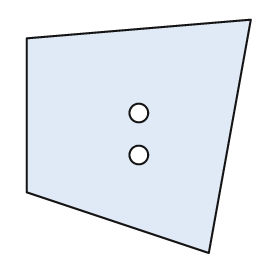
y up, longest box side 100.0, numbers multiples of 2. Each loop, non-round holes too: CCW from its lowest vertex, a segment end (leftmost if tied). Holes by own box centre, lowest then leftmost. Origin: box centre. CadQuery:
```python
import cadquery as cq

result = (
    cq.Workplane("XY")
    .moveTo(30.0, -50.0)
    .lineTo(48.0, 50.0)
    .lineTo(-48.0, 42.0)
    .lineTo(-48.0, -24.0)
    .close()
    .moveTo(0.0, -8.0)
    .circle(4.0)
    .moveTo(0.0, 10.0)
    .circle(4.0)
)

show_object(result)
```